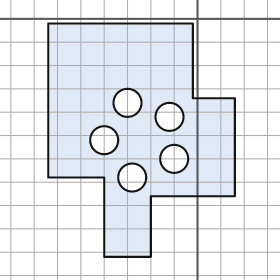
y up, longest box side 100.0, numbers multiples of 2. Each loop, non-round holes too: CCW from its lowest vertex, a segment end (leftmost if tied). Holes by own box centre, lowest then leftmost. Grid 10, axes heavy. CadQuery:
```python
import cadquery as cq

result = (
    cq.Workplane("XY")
    .moveTo(-40.0, -102.0)
    .lineTo(-20.0, -102.0)
    .lineTo(-20.0, -76.0)
    .lineTo(16.0, -76.0)
    .lineTo(16.0, -34.0)
    .lineTo(-2.0, -34.0)
    .lineTo(-2.0, -2.0)
    .lineTo(-64.0, -2.0)
    .lineTo(-64.0, -68.0)
    .lineTo(-40.0, -68.0)
    .close()
    .moveTo(-28.0, -68.0)
    .circle(6.0)
    .moveTo(-10.0, -60.0)
    .circle(6.0)
    .moveTo(-40.0, -52.0)
    .circle(6.0)
    .moveTo(-12.0, -42.0)
    .circle(6.0)
    .moveTo(-30.0, -36.0)
    .circle(6.0)
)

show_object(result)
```